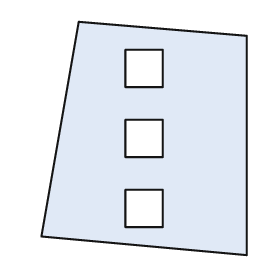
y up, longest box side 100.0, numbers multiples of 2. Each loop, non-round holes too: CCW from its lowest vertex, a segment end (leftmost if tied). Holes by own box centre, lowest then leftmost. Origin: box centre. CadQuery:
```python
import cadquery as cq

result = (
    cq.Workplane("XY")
    .moveTo(44.0, -50.0)
    .lineTo(44.0, 44.0)
    .lineTo(-28.0, 50.0)
    .lineTo(-44.0, -42.0)
    .close()
    .moveTo(-8.0, -38.0)
    .lineTo(8.0, -38.0)
    .lineTo(8.0, -22.0)
    .lineTo(-8.0, -22.0)
    .close()
    .moveTo(-8.0, -8.0)
    .lineTo(8.0, -8.0)
    .lineTo(8.0, 8.0)
    .lineTo(-8.0, 8.0)
    .close()
    .moveTo(-8.0, 22.0)
    .lineTo(8.0, 22.0)
    .lineTo(8.0, 38.0)
    .lineTo(-8.0, 38.0)
    .close()
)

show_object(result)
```